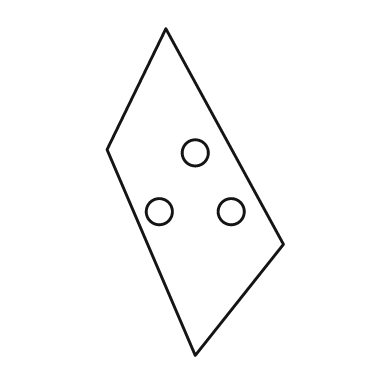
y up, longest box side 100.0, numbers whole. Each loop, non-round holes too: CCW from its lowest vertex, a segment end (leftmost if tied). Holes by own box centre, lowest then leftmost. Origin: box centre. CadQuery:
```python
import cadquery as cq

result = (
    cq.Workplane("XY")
    .moveTo(0.0, -50.0)
    .lineTo(27.0, -16.0)
    .lineTo(-9.0, 50.0)
    .lineTo(-27.0, 13.0)
    .close()
    .moveTo(-11.0, -6.0)
    .circle(4.0)
    .moveTo(11.0, -6.0)
    .circle(4.0)
    .moveTo(0.0, 12.0)
    .circle(4.0)
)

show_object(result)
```